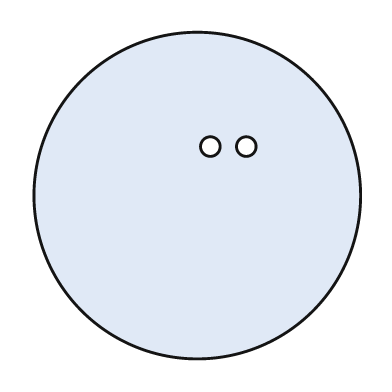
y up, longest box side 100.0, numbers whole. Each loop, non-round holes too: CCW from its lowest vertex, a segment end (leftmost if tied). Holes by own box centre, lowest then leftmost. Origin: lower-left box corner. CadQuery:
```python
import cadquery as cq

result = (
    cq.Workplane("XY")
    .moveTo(50.0, 50.0)
    .circle(50.0)
    .moveTo(54.0, 65.0)
    .circle(3.0)
    .moveTo(65.0, 65.0)
    .circle(3.0)
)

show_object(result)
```